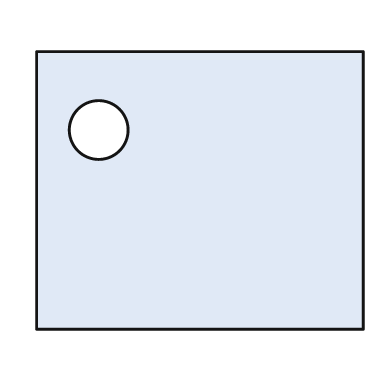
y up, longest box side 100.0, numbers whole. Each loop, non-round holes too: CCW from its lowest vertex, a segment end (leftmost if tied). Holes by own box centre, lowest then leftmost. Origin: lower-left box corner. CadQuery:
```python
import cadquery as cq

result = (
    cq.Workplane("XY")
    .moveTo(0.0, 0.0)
    .lineTo(100.0, 0.0)
    .lineTo(100.0, 85.0)
    .lineTo(0.0, 85.0)
    .close()
    .moveTo(19.0, 61.0)
    .circle(9.0)
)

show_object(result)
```